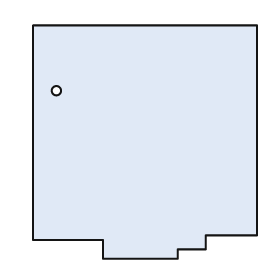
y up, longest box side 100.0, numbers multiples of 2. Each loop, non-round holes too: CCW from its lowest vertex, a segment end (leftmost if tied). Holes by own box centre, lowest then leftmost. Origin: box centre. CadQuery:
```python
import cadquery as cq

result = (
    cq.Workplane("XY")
    .moveTo(-18.0, -50.0)
    .lineTo(14.0, -50.0)
    .lineTo(14.0, -46.0)
    .lineTo(26.0, -46.0)
    .lineTo(26.0, -40.0)
    .lineTo(48.0, -40.0)
    .lineTo(48.0, 50.0)
    .lineTo(-48.0, 50.0)
    .lineTo(-48.0, -42.0)
    .lineTo(-18.0, -42.0)
    .close()
    .moveTo(-38.0, 22.0)
    .circle(2.0)
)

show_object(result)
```